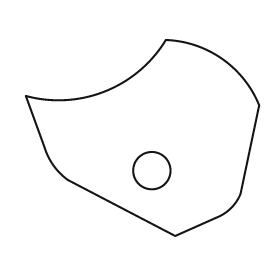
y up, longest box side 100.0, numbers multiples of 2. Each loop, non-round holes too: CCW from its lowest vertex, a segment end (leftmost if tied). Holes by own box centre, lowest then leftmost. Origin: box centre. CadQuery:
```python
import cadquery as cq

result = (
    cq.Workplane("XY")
    .moveTo(14.0, -42.0)
    .lineTo(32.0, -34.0)
    .threePointArc((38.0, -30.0), (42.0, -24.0))
    .lineTo(50.0, 14.0)
    .threePointArc((34.0, 34.0), (10.0, 42.0))
    .threePointArc((-16.0, 20.0), (-50.0, 18.0))
    .lineTo(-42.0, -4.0)
    .threePointArc((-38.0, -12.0), (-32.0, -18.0))
    .close()
    .moveTo(4.0, -14.0)
    .circle(8.0)
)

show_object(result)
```